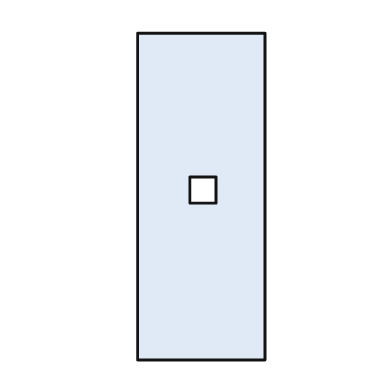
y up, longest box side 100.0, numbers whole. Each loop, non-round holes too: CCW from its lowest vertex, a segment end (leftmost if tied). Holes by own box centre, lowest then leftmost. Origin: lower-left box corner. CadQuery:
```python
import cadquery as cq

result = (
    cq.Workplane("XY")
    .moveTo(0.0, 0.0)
    .lineTo(39.0, 0.0)
    .lineTo(39.0, 100.0)
    .lineTo(0.0, 100.0)
    .close()
    .moveTo(16.0, 48.0)
    .lineTo(24.0, 48.0)
    .lineTo(24.0, 56.0)
    .lineTo(16.0, 56.0)
    .close()
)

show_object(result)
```